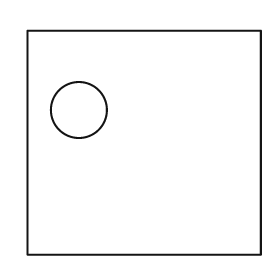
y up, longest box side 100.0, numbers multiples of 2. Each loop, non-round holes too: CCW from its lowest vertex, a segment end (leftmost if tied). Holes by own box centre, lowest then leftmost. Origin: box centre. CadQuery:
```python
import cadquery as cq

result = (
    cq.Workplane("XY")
    .moveTo(-50.0, -48.0)
    .lineTo(50.0, -48.0)
    .lineTo(50.0, 48.0)
    .lineTo(-50.0, 48.0)
    .close()
    .moveTo(-28.0, 14.0)
    .circle(12.0)
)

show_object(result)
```